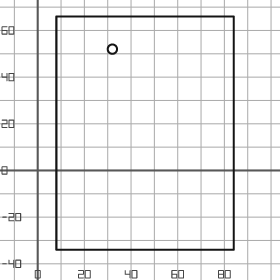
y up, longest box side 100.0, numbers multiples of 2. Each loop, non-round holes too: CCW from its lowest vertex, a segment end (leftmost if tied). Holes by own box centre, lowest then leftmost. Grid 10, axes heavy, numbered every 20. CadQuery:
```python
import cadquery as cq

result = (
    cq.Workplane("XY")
    .moveTo(8.0, -34.0)
    .lineTo(84.0, -34.0)
    .lineTo(84.0, 66.0)
    .lineTo(8.0, 66.0)
    .close()
    .moveTo(32.0, 52.0)
    .circle(2.0)
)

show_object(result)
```